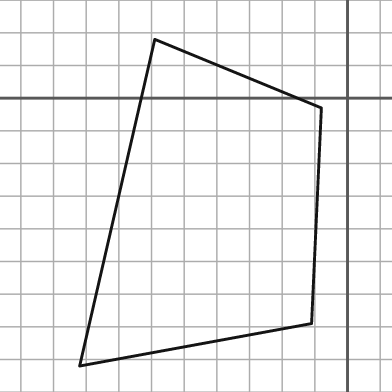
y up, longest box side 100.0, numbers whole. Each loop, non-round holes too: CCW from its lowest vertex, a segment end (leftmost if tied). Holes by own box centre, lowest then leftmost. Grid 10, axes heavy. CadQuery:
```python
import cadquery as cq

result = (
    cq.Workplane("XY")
    .moveTo(-82.0, -82.0)
    .lineTo(-11.0, -69.0)
    .lineTo(-8.0, -3.0)
    .lineTo(-59.0, 18.0)
    .close()
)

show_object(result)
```